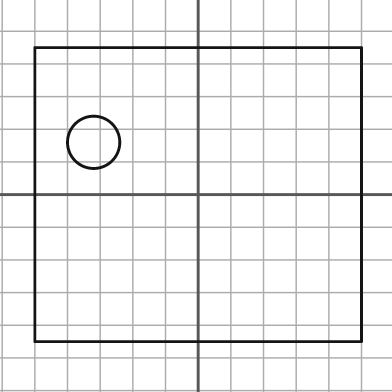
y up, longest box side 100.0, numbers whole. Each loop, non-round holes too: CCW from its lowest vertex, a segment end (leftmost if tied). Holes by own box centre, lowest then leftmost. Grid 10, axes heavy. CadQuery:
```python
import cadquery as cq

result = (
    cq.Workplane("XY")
    .moveTo(-50.0, -45.0)
    .lineTo(50.0, -45.0)
    .lineTo(50.0, 45.0)
    .lineTo(-50.0, 45.0)
    .close()
    .moveTo(-32.0, 16.0)
    .circle(8.0)
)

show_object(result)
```